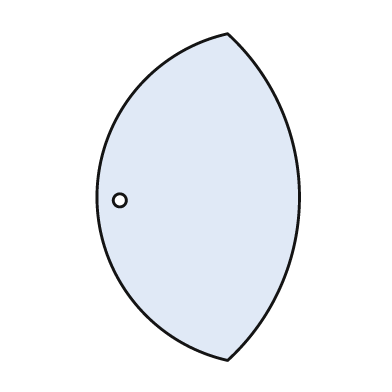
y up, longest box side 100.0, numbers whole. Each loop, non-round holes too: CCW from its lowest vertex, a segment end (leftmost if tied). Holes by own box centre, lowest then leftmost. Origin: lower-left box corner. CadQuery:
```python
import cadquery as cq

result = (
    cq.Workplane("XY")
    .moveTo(40.0, 0.0)
    .threePointArc((62.0, 50.0), (40.0, 100.0))
    .threePointArc((0.0, 50.0), (40.0, 0.0))
    .close()
    .moveTo(7.0, 49.0)
    .circle(2.0)
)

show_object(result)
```